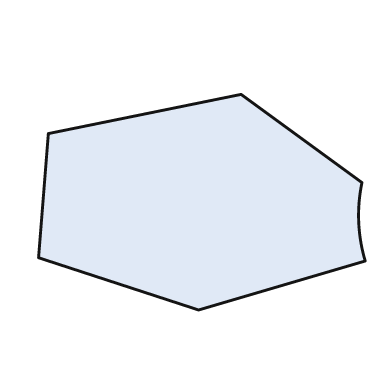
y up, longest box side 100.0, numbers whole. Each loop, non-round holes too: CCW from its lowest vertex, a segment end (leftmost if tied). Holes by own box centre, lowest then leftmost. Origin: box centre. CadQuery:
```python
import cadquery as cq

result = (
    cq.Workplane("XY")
    .moveTo(-1.0, -33.0)
    .lineTo(50.0, -18.0)
    .threePointArc((48.0, -6.0), (49.0, 6.0))
    .lineTo(12.0, 33.0)
    .lineTo(-47.0, 21.0)
    .lineTo(-50.0, -17.0)
    .close()
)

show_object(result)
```